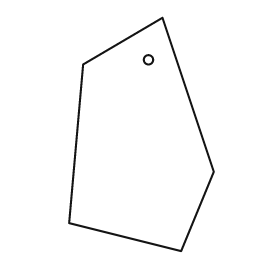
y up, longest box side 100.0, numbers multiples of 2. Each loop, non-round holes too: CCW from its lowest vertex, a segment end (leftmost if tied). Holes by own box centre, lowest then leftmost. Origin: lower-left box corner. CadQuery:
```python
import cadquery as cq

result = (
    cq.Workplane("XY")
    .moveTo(48.0, 0.0)
    .lineTo(62.0, 34.0)
    .lineTo(40.0, 100.0)
    .lineTo(6.0, 80.0)
    .lineTo(0.0, 12.0)
    .close()
    .moveTo(34.0, 82.0)
    .circle(2.0)
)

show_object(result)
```